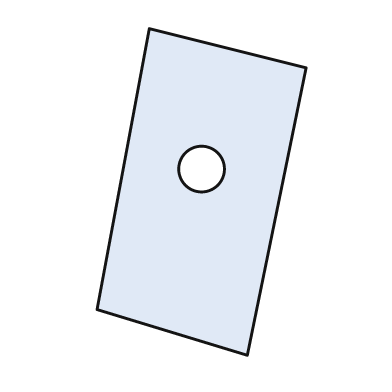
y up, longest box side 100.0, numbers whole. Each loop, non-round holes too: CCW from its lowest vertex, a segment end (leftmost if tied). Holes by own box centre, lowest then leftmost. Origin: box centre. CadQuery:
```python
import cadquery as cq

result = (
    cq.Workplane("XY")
    .moveTo(14.0, -50.0)
    .lineTo(32.0, 38.0)
    .lineTo(-16.0, 50.0)
    .lineTo(-32.0, -36.0)
    .close()
    .moveTo(0.0, 7.0)
    .circle(7.0)
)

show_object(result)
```